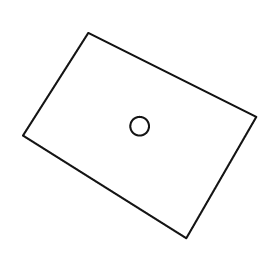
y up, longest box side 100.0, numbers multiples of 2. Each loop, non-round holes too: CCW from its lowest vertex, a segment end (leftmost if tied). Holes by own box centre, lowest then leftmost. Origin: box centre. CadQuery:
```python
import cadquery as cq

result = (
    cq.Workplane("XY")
    .moveTo(20.0, -44.0)
    .lineTo(50.0, 8.0)
    .lineTo(-22.0, 44.0)
    .lineTo(-50.0, 0.0)
    .close()
    .moveTo(0.0, 4.0)
    .circle(4.0)
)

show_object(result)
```